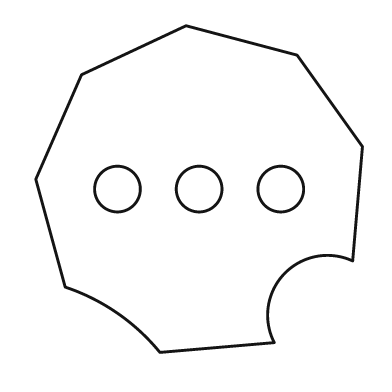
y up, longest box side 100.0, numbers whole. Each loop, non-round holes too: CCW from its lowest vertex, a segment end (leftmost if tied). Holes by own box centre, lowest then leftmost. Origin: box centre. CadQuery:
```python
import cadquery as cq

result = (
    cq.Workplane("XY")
    .moveTo(-12.0, -50.0)
    .lineTo(23.0, -47.0)
    .threePointArc((26.0, -26.0), (47.0, -22.0))
    .lineTo(50.0, 13.0)
    .lineTo(30.0, 41.0)
    .lineTo(-4.0, 50.0)
    .lineTo(-36.0, 35.0)
    .lineTo(-50.0, 3.0)
    .lineTo(-41.0, -30.0)
    .threePointArc((-25.0, -38.0), (-12.0, -50.0))
    .close()
    .moveTo(-25.0, 0.0)
    .circle(7.0)
    .moveTo(0.0, 0.0)
    .circle(7.0)
    .moveTo(25.0, 0.0)
    .circle(7.0)
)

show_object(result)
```